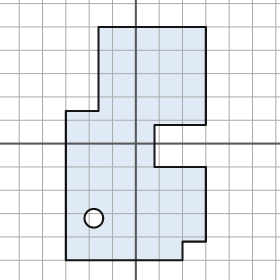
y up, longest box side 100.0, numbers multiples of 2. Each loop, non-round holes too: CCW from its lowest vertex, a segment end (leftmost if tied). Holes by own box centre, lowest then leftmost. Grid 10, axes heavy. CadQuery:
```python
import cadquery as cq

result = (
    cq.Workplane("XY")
    .moveTo(-30.0, -50.0)
    .lineTo(20.0, -50.0)
    .lineTo(20.0, -42.0)
    .lineTo(30.0, -42.0)
    .lineTo(30.0, -10.0)
    .lineTo(8.0, -10.0)
    .lineTo(8.0, 8.0)
    .lineTo(30.0, 8.0)
    .lineTo(30.0, 50.0)
    .lineTo(-16.0, 50.0)
    .lineTo(-16.0, 14.0)
    .lineTo(-30.0, 14.0)
    .close()
    .moveTo(-18.0, -32.0)
    .circle(4.0)
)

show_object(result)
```